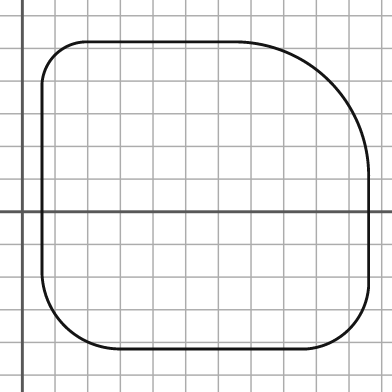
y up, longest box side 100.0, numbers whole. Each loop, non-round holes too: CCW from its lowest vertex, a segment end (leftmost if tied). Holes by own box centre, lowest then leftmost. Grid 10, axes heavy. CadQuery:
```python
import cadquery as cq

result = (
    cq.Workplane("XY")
    .moveTo(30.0, -42.0)
    .lineTo(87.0, -42.0)
    .threePointArc((100.0, -36.0), (106.0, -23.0))
    .lineTo(106.0, 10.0)
    .threePointArc((94.0, 40.0), (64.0, 52.0))
    .lineTo(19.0, 52.0)
    .threePointArc((10.0, 48.0), (6.0, 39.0))
    .lineTo(6.0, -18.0)
    .threePointArc((13.0, -35.0), (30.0, -42.0))
    .close()
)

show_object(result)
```